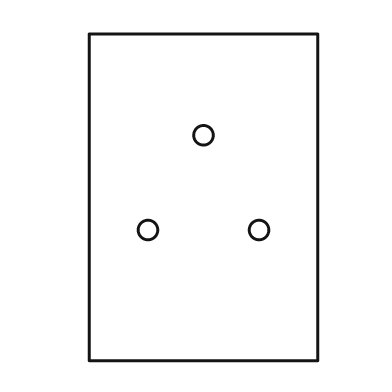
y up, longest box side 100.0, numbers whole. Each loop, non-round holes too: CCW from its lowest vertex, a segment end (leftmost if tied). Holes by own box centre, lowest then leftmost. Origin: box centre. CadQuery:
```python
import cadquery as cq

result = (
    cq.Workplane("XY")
    .moveTo(-35.0, -50.0)
    .lineTo(35.0, -50.0)
    .lineTo(35.0, 50.0)
    .lineTo(-35.0, 50.0)
    .close()
    .moveTo(-17.0, -10.0)
    .circle(3.0)
    .moveTo(17.0, -10.0)
    .circle(3.0)
    .moveTo(0.0, 19.0)
    .circle(3.0)
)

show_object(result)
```